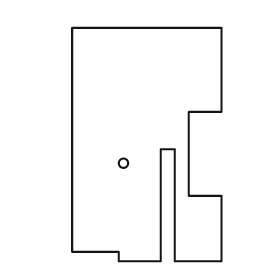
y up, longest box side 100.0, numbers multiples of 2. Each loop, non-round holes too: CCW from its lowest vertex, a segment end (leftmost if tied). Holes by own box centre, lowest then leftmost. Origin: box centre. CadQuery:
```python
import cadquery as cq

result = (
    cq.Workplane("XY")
    .moveTo(-12.0, -50.0)
    .lineTo(6.0, -50.0)
    .lineTo(6.0, -2.0)
    .lineTo(12.0, -2.0)
    .lineTo(12.0, -50.0)
    .lineTo(32.0, -50.0)
    .lineTo(32.0, -22.0)
    .lineTo(18.0, -22.0)
    .lineTo(18.0, 14.0)
    .lineTo(32.0, 14.0)
    .lineTo(32.0, 50.0)
    .lineTo(-32.0, 50.0)
    .lineTo(-32.0, -46.0)
    .lineTo(-12.0, -46.0)
    .close()
    .moveTo(-10.0, -8.0)
    .circle(2.0)
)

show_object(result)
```